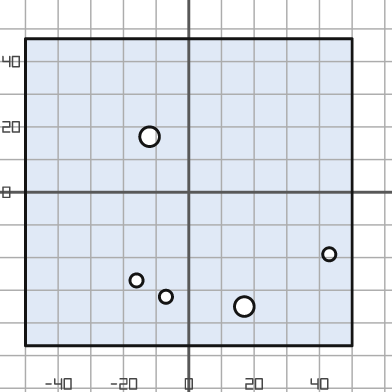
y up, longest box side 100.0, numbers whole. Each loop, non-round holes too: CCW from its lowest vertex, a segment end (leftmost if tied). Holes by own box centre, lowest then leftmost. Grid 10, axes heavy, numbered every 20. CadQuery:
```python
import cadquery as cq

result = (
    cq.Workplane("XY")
    .moveTo(-50.0, -47.0)
    .lineTo(50.0, -47.0)
    .lineTo(50.0, 47.0)
    .lineTo(-50.0, 47.0)
    .close()
    .moveTo(17.0, -35.0)
    .circle(3.0)
    .moveTo(-7.0, -32.0)
    .circle(2.0)
    .moveTo(-16.0, -27.0)
    .circle(2.0)
    .moveTo(43.0, -19.0)
    .circle(2.0)
    .moveTo(-12.0, 17.0)
    .circle(3.0)
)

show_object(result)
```